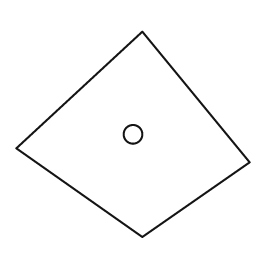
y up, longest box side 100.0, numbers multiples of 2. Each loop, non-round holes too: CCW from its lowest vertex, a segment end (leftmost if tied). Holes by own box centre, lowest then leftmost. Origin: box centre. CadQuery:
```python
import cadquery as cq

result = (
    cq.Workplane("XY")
    .moveTo(4.0, -44.0)
    .lineTo(50.0, -12.0)
    .lineTo(4.0, 44.0)
    .lineTo(-50.0, -6.0)
    .close()
    .moveTo(0.0, 0.0)
    .circle(4.0)
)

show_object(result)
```